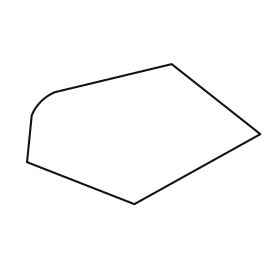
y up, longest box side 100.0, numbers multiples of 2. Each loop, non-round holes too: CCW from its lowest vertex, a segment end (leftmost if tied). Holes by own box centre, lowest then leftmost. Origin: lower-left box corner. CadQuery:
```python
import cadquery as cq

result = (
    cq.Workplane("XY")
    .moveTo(46.0, 0.0)
    .lineTo(100.0, 30.0)
    .lineTo(62.0, 60.0)
    .lineTo(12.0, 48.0)
    .threePointArc((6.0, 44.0), (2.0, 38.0))
    .lineTo(0.0, 18.0)
    .close()
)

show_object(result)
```